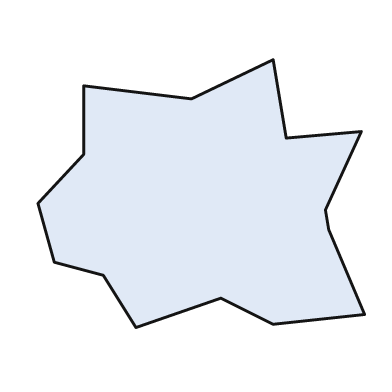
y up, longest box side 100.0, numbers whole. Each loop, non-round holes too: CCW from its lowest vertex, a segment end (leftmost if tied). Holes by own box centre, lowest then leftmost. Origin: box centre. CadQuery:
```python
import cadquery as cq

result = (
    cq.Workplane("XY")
    .moveTo(-20.0, -41.0)
    .lineTo(6.0, -32.0)
    .lineTo(22.0, -40.0)
    .lineTo(50.0, -37.0)
    .lineTo(39.0, -11.0)
    .lineTo(38.0, -5.0)
    .lineTo(49.0, 19.0)
    .lineTo(26.0, 17.0)
    .lineTo(22.0, 41.0)
    .lineTo(-3.0, 29.0)
    .lineTo(-36.0, 33.0)
    .lineTo(-36.0, 12.0)
    .lineTo(-50.0, -3.0)
    .lineTo(-45.0, -21.0)
    .lineTo(-30.0, -25.0)
    .close()
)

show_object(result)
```